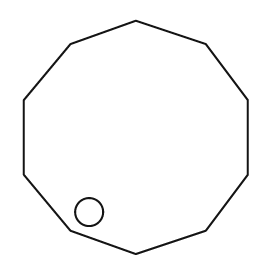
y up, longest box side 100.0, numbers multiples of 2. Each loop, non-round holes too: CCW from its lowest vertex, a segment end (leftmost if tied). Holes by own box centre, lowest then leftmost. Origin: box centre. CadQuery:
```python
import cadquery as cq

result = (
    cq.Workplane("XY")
    .moveTo(0.0, -50.0)
    .lineTo(30.0, -40.0)
    .lineTo(48.0, -16.0)
    .lineTo(48.0, 16.0)
    .lineTo(30.0, 40.0)
    .lineTo(0.0, 50.0)
    .lineTo(-28.0, 40.0)
    .lineTo(-48.0, 16.0)
    .lineTo(-48.0, -16.0)
    .lineTo(-28.0, -40.0)
    .close()
    .moveTo(-20.0, -32.0)
    .circle(6.0)
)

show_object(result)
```